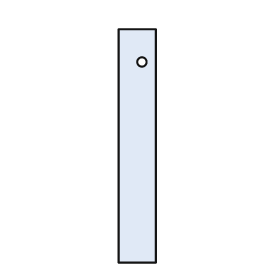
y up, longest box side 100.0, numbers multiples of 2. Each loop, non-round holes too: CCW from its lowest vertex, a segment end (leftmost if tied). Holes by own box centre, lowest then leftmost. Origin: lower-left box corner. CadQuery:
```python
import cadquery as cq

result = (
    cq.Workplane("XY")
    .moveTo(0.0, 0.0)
    .lineTo(16.0, 0.0)
    .lineTo(16.0, 100.0)
    .lineTo(0.0, 100.0)
    .close()
    .moveTo(10.0, 86.0)
    .circle(2.0)
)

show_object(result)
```